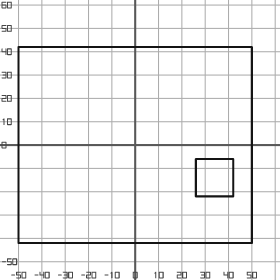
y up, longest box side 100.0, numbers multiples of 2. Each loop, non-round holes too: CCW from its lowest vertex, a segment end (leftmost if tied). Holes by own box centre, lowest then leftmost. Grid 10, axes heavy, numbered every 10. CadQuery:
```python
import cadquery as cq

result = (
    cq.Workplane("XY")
    .moveTo(-50.0, -42.0)
    .lineTo(50.0, -42.0)
    .lineTo(50.0, 42.0)
    .lineTo(-50.0, 42.0)
    .close()
    .moveTo(26.0, -22.0)
    .lineTo(42.0, -22.0)
    .lineTo(42.0, -6.0)
    .lineTo(26.0, -6.0)
    .close()
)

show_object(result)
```